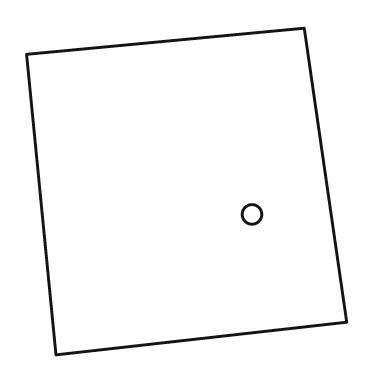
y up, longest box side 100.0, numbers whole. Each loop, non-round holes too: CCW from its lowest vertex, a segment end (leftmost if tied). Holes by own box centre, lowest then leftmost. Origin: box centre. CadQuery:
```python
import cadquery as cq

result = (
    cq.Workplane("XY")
    .moveTo(-40.0, -50.0)
    .lineTo(49.0, -40.0)
    .lineTo(36.0, 50.0)
    .lineTo(-49.0, 42.0)
    .close()
    .moveTo(20.0, -7.0)
    .circle(3.0)
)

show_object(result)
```